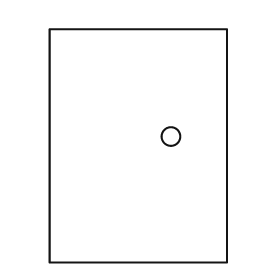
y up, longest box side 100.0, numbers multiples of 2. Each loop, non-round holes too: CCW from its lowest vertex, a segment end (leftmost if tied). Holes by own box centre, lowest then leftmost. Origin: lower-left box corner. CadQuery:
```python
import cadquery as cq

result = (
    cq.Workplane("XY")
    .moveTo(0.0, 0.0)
    .lineTo(76.0, 0.0)
    .lineTo(76.0, 100.0)
    .lineTo(0.0, 100.0)
    .close()
    .moveTo(52.0, 54.0)
    .circle(4.0)
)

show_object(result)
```